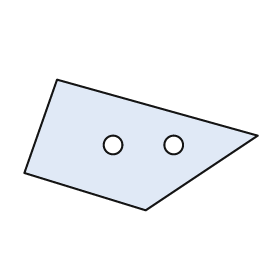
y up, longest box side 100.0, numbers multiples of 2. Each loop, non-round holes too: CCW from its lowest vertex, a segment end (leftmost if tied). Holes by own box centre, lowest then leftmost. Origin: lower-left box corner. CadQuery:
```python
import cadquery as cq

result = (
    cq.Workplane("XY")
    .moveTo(52.0, 0.0)
    .lineTo(100.0, 32.0)
    .lineTo(14.0, 56.0)
    .lineTo(0.0, 16.0)
    .close()
    .moveTo(38.0, 28.0)
    .circle(4.0)
    .moveTo(64.0, 28.0)
    .circle(4.0)
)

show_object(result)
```